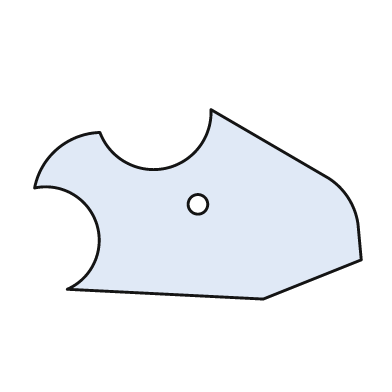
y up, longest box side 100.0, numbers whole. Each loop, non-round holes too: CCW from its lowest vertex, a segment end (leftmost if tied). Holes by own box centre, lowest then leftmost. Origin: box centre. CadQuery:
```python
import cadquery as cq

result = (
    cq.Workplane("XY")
    .moveTo(20.0, -29.0)
    .lineTo(50.0, -17.0)
    .lineTo(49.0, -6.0)
    .threePointArc((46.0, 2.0), (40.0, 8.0))
    .lineTo(4.0, 29.0)
    .threePointArc((-10.0, 11.0), (-30.0, 22.0))
    .threePointArc((-43.0, 17.0), (-50.0, 5.0))
    .threePointArc((-31.0, -6.0), (-40.0, -26.0))
    .close()
    .moveTo(0.0, 0.0)
    .circle(3.0)
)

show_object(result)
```